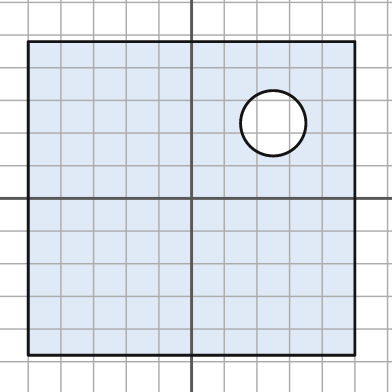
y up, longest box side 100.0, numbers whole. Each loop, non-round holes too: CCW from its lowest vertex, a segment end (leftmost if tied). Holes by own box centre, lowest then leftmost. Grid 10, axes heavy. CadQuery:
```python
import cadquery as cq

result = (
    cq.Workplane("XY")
    .moveTo(-50.0, -48.0)
    .lineTo(50.0, -48.0)
    .lineTo(50.0, 48.0)
    .lineTo(-50.0, 48.0)
    .close()
    .moveTo(25.0, 23.0)
    .circle(10.0)
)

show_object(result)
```